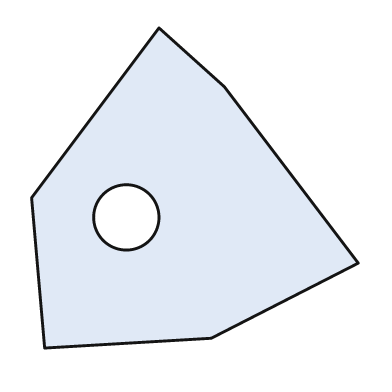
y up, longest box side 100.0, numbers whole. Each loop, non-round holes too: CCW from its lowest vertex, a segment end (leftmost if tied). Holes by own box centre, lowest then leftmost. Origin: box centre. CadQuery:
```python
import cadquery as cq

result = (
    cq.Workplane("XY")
    .moveTo(-46.0, -49.0)
    .lineTo(5.0, -46.0)
    .lineTo(50.0, -23.0)
    .lineTo(9.0, 31.0)
    .lineTo(-11.0, 49.0)
    .lineTo(-50.0, -3.0)
    .close()
    .moveTo(-21.0, -9.0)
    .circle(10.0)
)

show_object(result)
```